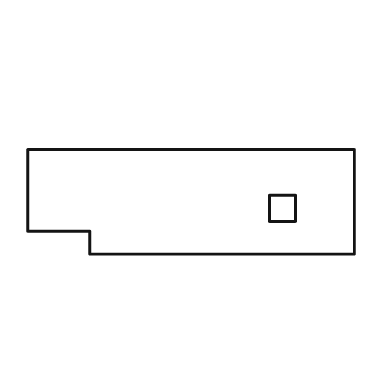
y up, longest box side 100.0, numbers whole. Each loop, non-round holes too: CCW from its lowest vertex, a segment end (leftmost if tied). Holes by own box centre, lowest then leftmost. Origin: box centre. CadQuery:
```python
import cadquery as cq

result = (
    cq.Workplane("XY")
    .moveTo(-31.0, -16.0)
    .lineTo(50.0, -16.0)
    .lineTo(50.0, 16.0)
    .lineTo(-50.0, 16.0)
    .lineTo(-50.0, -9.0)
    .lineTo(-31.0, -9.0)
    .close()
    .moveTo(24.0, -6.0)
    .lineTo(32.0, -6.0)
    .lineTo(32.0, 2.0)
    .lineTo(24.0, 2.0)
    .close()
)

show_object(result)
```